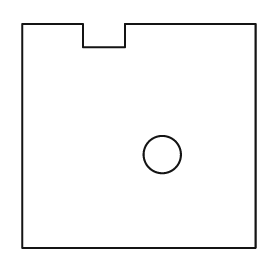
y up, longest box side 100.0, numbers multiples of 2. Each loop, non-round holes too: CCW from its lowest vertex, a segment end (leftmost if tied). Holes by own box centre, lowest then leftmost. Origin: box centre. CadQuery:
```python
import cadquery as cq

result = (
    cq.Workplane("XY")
    .moveTo(-50.0, -48.0)
    .lineTo(50.0, -48.0)
    .lineTo(50.0, 48.0)
    .lineTo(-6.0, 48.0)
    .lineTo(-6.0, 38.0)
    .lineTo(-24.0, 38.0)
    .lineTo(-24.0, 48.0)
    .lineTo(-50.0, 48.0)
    .close()
    .moveTo(10.0, -8.0)
    .circle(8.0)
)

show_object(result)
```